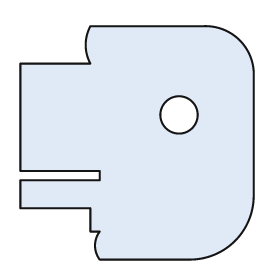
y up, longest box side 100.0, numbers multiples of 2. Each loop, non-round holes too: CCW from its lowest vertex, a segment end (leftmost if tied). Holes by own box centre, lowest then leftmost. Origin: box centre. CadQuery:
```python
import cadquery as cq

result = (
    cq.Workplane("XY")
    .moveTo(-16.0, -50.0)
    .lineTo(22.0, -50.0)
    .threePointArc((42.0, -42.0), (50.0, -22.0))
    .lineTo(50.0, 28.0)
    .threePointArc((44.0, 44.0), (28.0, 50.0))
    .lineTo(-20.0, 50.0)
    .threePointArc((-22.0, 42.0), (-20.0, 34.0))
    .lineTo(-50.0, 34.0)
    .lineTo(-50.0, -12.0)
    .lineTo(-16.0, -12.0)
    .lineTo(-16.0, -16.0)
    .lineTo(-50.0, -16.0)
    .lineTo(-50.0, -28.0)
    .lineTo(-20.0, -28.0)
    .lineTo(-20.0, -38.0)
    .lineTo(-16.0, -38.0)
    .threePointArc((-18.0, -44.0), (-16.0, -50.0))
    .close()
    .moveTo(18.0, 12.0)
    .circle(8.0)
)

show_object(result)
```